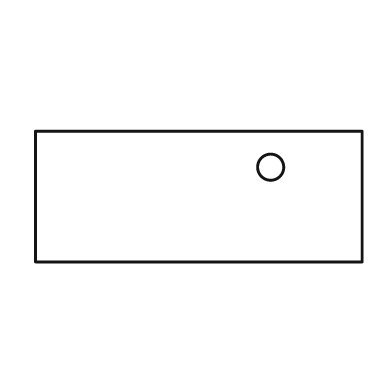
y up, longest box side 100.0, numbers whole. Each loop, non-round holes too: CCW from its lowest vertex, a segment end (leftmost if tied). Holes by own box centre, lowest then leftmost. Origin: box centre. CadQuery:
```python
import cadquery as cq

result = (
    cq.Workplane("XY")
    .moveTo(-50.0, -20.0)
    .lineTo(50.0, -20.0)
    .lineTo(50.0, 20.0)
    .lineTo(-50.0, 20.0)
    .close()
    .moveTo(22.0, 9.0)
    .circle(4.0)
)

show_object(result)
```